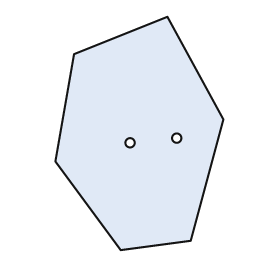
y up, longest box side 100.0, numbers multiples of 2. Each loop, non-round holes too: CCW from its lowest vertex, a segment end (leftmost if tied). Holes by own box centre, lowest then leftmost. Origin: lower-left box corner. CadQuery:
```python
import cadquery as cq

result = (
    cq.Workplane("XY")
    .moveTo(28.0, 0.0)
    .lineTo(58.0, 4.0)
    .lineTo(72.0, 56.0)
    .lineTo(48.0, 100.0)
    .lineTo(8.0, 84.0)
    .lineTo(0.0, 38.0)
    .close()
    .moveTo(32.0, 46.0)
    .circle(2.0)
    .moveTo(52.0, 48.0)
    .circle(2.0)
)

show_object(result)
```